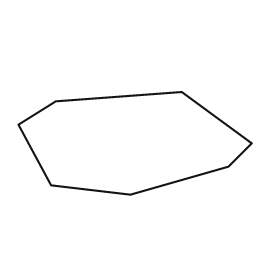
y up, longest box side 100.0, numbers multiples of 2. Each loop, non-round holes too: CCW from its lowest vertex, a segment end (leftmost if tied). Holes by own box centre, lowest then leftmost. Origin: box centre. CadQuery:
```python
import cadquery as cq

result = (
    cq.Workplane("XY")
    .moveTo(-2.0, -22.0)
    .lineTo(40.0, -10.0)
    .lineTo(50.0, 0.0)
    .lineTo(20.0, 22.0)
    .lineTo(-34.0, 18.0)
    .lineTo(-50.0, 8.0)
    .lineTo(-36.0, -18.0)
    .close()
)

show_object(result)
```